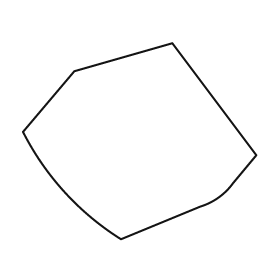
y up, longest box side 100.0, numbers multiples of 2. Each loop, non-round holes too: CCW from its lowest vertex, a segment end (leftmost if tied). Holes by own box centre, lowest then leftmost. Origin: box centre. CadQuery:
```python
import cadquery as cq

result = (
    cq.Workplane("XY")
    .moveTo(-8.0, -42.0)
    .lineTo(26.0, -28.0)
    .threePointArc((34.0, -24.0), (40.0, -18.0))
    .lineTo(50.0, -6.0)
    .lineTo(14.0, 42.0)
    .lineTo(-28.0, 30.0)
    .lineTo(-50.0, 4.0)
    .threePointArc((-32.0, -22.0), (-8.0, -42.0))
    .close()
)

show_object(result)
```